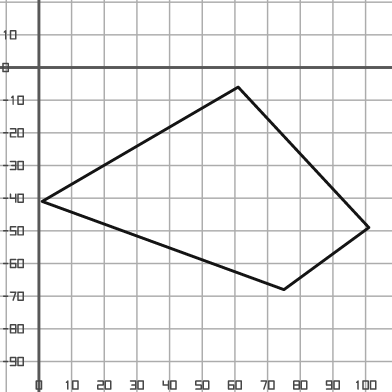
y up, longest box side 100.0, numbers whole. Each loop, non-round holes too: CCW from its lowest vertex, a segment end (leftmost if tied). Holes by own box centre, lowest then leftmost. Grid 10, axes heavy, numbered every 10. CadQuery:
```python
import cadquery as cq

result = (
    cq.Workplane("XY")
    .moveTo(75.0, -68.0)
    .lineTo(101.0, -49.0)
    .lineTo(61.0, -6.0)
    .lineTo(1.0, -41.0)
    .close()
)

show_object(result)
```